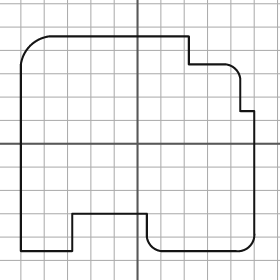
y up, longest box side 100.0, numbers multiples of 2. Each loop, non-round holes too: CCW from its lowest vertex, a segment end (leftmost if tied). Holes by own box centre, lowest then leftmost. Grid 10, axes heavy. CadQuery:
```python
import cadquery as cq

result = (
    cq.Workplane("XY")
    .moveTo(-50.0, -46.0)
    .lineTo(-28.0, -46.0)
    .lineTo(-28.0, -30.0)
    .lineTo(4.0, -30.0)
    .lineTo(4.0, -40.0)
    .threePointArc((6.0, -44.0), (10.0, -46.0))
    .lineTo(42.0, -46.0)
    .threePointArc((48.0, -44.0), (50.0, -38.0))
    .lineTo(50.0, 14.0)
    .lineTo(44.0, 14.0)
    .lineTo(44.0, 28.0)
    .threePointArc((42.0, 32.0), (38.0, 34.0))
    .lineTo(22.0, 34.0)
    .lineTo(22.0, 46.0)
    .lineTo(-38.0, 46.0)
    .threePointArc((-46.0, 42.0), (-50.0, 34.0))
    .close()
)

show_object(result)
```